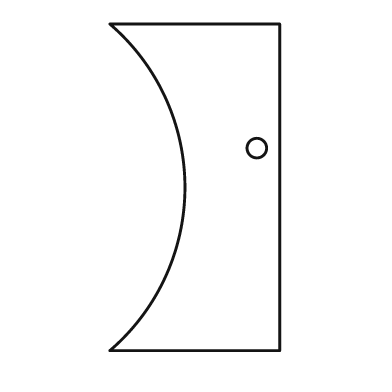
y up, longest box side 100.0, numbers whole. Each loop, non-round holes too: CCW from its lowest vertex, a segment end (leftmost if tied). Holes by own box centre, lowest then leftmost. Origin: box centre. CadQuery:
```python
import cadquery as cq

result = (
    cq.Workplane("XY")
    .moveTo(-26.0, -50.0)
    .lineTo(26.0, -50.0)
    .lineTo(26.0, 50.0)
    .lineTo(-26.0, 50.0)
    .threePointArc((-3.0, 0.0), (-26.0, -50.0))
    .close()
    .moveTo(19.0, 12.0)
    .circle(3.0)
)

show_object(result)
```